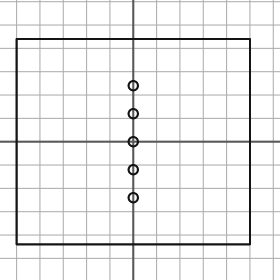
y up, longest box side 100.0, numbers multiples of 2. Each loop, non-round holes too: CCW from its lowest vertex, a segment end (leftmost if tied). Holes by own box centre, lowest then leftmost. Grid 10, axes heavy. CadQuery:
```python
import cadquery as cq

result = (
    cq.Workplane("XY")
    .moveTo(-50.0, -44.0)
    .lineTo(50.0, -44.0)
    .lineTo(50.0, 44.0)
    .lineTo(-50.0, 44.0)
    .close()
    .moveTo(0.0, -24.0)
    .circle(2.0)
    .moveTo(0.0, -12.0)
    .circle(2.0)
    .moveTo(0.0, 0.0)
    .circle(2.0)
    .moveTo(0.0, 12.0)
    .circle(2.0)
    .moveTo(0.0, 24.0)
    .circle(2.0)
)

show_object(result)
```